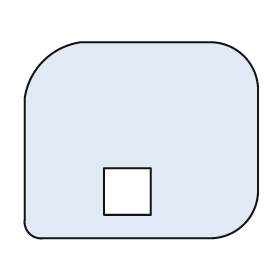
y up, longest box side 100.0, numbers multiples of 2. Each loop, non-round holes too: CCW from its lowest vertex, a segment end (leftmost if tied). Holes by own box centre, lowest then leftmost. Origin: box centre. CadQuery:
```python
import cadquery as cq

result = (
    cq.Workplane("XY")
    .moveTo(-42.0, -42.0)
    .lineTo(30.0, -42.0)
    .threePointArc((44.0, -36.0), (50.0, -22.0))
    .lineTo(50.0, 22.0)
    .threePointArc((44.0, 36.0), (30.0, 42.0))
    .lineTo(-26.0, 42.0)
    .threePointArc((-42.0, 34.0), (-50.0, 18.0))
    .lineTo(-50.0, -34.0)
    .threePointArc((-48.0, -40.0), (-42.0, -42.0))
    .close()
    .moveTo(-16.0, -32.0)
    .lineTo(4.0, -32.0)
    .lineTo(4.0, -12.0)
    .lineTo(-16.0, -12.0)
    .close()
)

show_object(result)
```